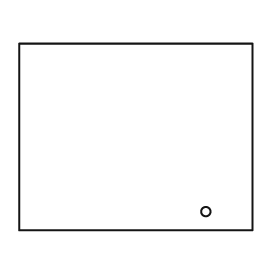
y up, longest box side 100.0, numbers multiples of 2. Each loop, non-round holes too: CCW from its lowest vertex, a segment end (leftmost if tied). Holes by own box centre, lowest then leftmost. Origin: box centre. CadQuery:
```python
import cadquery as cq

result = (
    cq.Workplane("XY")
    .moveTo(-50.0, -40.0)
    .lineTo(50.0, -40.0)
    .lineTo(50.0, 40.0)
    .lineTo(-50.0, 40.0)
    .close()
    .moveTo(30.0, -32.0)
    .circle(2.0)
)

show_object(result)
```